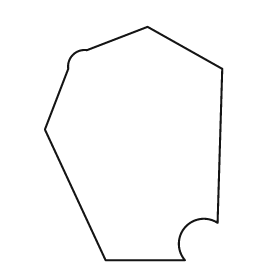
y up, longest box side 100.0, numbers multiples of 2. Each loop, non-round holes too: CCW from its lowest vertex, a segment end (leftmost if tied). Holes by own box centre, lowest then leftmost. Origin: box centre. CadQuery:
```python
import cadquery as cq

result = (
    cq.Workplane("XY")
    .moveTo(-12.0, -50.0)
    .lineTo(22.0, -50.0)
    .threePointArc((22.0, -36.0), (36.0, -34.0))
    .lineTo(38.0, 32.0)
    .lineTo(6.0, 50.0)
    .lineTo(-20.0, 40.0)
    .threePointArc((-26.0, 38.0), (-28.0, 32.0))
    .lineTo(-38.0, 6.0)
    .close()
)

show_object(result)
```